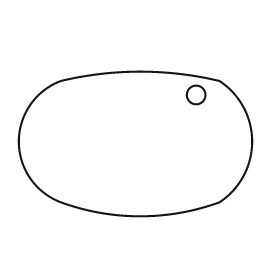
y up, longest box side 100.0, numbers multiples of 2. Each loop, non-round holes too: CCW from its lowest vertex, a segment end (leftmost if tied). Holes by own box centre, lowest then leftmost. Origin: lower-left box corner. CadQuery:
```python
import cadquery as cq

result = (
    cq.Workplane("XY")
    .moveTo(18.0, 6.0)
    .threePointArc((52.0, 0.0), (86.0, 6.0))
    .threePointArc((100.0, 32.0), (86.0, 58.0))
    .threePointArc((52.0, 62.0), (18.0, 58.0))
    .threePointArc((0.0, 32.0), (18.0, 6.0))
    .close()
    .moveTo(76.0, 52.0)
    .circle(4.0)
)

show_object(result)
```